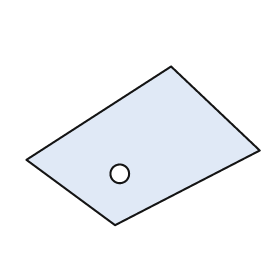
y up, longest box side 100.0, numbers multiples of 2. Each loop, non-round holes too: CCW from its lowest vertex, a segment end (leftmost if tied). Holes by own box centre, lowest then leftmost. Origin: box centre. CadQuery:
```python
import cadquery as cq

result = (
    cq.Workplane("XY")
    .moveTo(-12.0, -34.0)
    .lineTo(50.0, -2.0)
    .lineTo(12.0, 34.0)
    .lineTo(-50.0, -6.0)
    .close()
    .moveTo(-10.0, -12.0)
    .circle(4.0)
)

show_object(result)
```